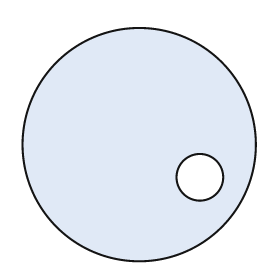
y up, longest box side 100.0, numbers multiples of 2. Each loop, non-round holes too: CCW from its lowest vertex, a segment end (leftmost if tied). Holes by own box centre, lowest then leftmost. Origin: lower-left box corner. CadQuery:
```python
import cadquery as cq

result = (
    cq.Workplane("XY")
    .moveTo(50.0, 50.0)
    .circle(50.0)
    .moveTo(76.0, 36.0)
    .circle(10.0)
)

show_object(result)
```